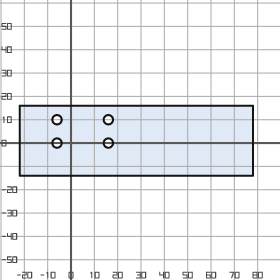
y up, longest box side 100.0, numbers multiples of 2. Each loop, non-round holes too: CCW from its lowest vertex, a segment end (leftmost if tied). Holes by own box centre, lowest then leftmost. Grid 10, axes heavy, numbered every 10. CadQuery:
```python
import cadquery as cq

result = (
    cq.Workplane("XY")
    .moveTo(-22.0, -14.0)
    .lineTo(78.0, -14.0)
    .lineTo(78.0, 16.0)
    .lineTo(-22.0, 16.0)
    .close()
    .moveTo(-6.0, 0.0)
    .circle(2.0)
    .moveTo(16.0, 0.0)
    .circle(2.0)
    .moveTo(-6.0, 10.0)
    .circle(2.0)
    .moveTo(16.0, 10.0)
    .circle(2.0)
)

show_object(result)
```